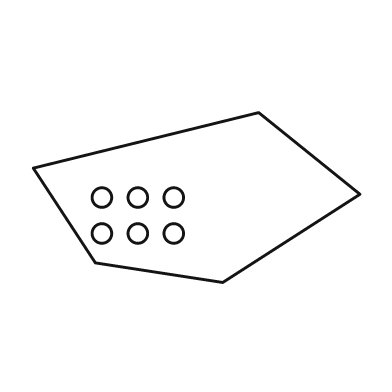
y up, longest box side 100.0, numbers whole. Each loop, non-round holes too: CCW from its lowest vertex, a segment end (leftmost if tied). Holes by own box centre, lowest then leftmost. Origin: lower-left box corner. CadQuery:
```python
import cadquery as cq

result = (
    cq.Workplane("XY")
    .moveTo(58.0, 0.0)
    .lineTo(100.0, 27.0)
    .lineTo(69.0, 52.0)
    .lineTo(0.0, 35.0)
    .lineTo(19.0, 6.0)
    .close()
    .moveTo(21.0, 15.0)
    .circle(3.0)
    .moveTo(32.0, 15.0)
    .circle(3.0)
    .moveTo(43.0, 15.0)
    .circle(3.0)
    .moveTo(21.0, 26.0)
    .circle(3.0)
    .moveTo(32.0, 26.0)
    .circle(3.0)
    .moveTo(43.0, 26.0)
    .circle(3.0)
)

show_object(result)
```